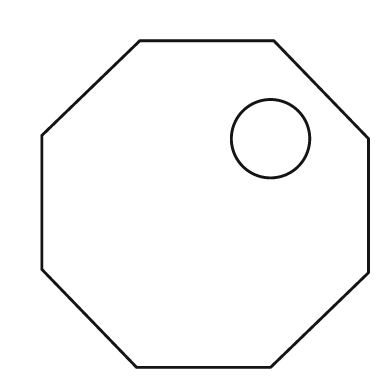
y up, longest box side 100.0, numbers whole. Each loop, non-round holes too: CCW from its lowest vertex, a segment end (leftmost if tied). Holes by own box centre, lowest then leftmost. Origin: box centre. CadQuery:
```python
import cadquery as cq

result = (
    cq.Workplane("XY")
    .moveTo(-21.0, -50.0)
    .lineTo(20.0, -50.0)
    .lineTo(50.0, -21.0)
    .lineTo(50.0, 20.0)
    .lineTo(21.0, 50.0)
    .lineTo(-20.0, 50.0)
    .lineTo(-50.0, 21.0)
    .lineTo(-50.0, -20.0)
    .close()
    .moveTo(20.0, 20.0)
    .circle(12.0)
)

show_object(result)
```